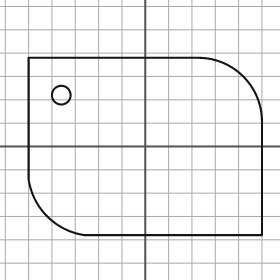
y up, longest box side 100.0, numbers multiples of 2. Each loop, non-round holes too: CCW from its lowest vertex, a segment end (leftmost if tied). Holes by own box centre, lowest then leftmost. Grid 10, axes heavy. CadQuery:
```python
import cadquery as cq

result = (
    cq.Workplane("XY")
    .moveTo(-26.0, -38.0)
    .lineTo(50.0, -38.0)
    .lineTo(50.0, 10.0)
    .threePointArc((42.0, 30.0), (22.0, 38.0))
    .lineTo(-50.0, 38.0)
    .lineTo(-50.0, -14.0)
    .threePointArc((-42.0, -30.0), (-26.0, -38.0))
    .close()
    .moveTo(-36.0, 22.0)
    .circle(4.0)
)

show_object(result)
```